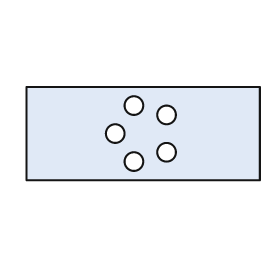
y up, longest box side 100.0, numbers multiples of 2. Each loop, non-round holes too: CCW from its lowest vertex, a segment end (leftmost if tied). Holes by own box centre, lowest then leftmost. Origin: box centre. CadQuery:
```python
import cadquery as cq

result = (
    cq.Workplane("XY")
    .moveTo(-50.0, -20.0)
    .lineTo(50.0, -20.0)
    .lineTo(50.0, 20.0)
    .lineTo(-50.0, 20.0)
    .close()
    .moveTo(-4.0, -12.0)
    .circle(4.0)
    .moveTo(10.0, -8.0)
    .circle(4.0)
    .moveTo(-12.0, 0.0)
    .circle(4.0)
    .moveTo(10.0, 8.0)
    .circle(4.0)
    .moveTo(-4.0, 12.0)
    .circle(4.0)
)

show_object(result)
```